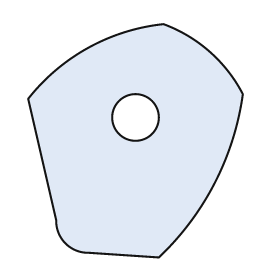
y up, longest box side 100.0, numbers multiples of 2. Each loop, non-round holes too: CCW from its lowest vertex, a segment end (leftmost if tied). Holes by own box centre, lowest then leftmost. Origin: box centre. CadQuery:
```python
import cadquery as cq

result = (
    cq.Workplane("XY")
    .moveTo(10.0, -50.0)
    .threePointArc((34.0, -18.0), (46.0, 20.0))
    .threePointArc((32.0, 38.0), (12.0, 50.0))
    .threePointArc((-20.0, 40.0), (-46.0, 18.0))
    .lineTo(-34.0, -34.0)
    .threePointArc((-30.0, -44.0), (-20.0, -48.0))
    .close()
    .moveTo(0.0, 10.0)
    .circle(10.0)
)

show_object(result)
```